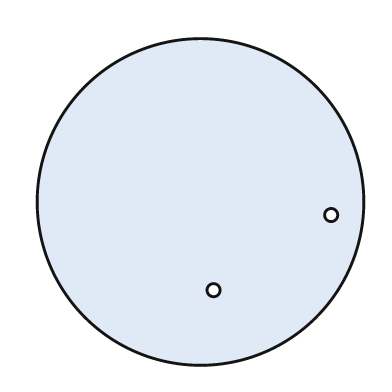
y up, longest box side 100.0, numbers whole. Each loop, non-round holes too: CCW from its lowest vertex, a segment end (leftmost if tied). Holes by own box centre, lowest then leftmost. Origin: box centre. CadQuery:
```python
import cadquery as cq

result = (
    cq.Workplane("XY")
    .moveTo(0.0, 0.0)
    .circle(50.0)
    .moveTo(4.0, -27.0)
    .circle(2.0)
    .moveTo(40.0, -4.0)
    .circle(2.0)
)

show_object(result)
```